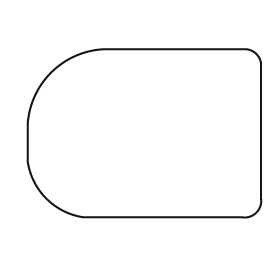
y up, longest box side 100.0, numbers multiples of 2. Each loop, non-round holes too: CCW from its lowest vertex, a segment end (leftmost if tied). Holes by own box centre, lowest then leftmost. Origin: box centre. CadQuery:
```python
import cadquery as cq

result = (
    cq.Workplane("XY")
    .moveTo(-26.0, -36.0)
    .lineTo(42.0, -36.0)
    .threePointArc((48.0, -34.0), (50.0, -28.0))
    .lineTo(50.0, 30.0)
    .threePointArc((48.0, 34.0), (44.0, 36.0))
    .lineTo(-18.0, 36.0)
    .threePointArc((-40.0, 26.0), (-50.0, 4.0))
    .lineTo(-50.0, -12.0)
    .threePointArc((-42.0, -28.0), (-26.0, -36.0))
    .close()
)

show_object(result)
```